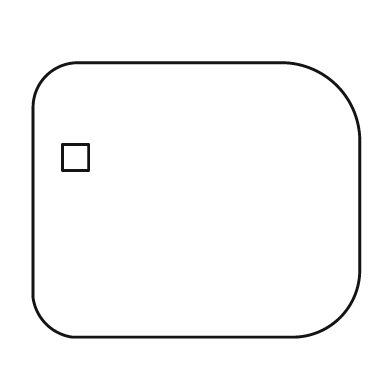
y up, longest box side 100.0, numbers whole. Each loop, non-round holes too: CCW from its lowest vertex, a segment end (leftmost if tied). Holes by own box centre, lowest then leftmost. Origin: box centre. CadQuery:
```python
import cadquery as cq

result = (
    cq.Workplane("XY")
    .moveTo(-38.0, -42.0)
    .lineTo(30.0, -42.0)
    .threePointArc((44.0, -36.0), (50.0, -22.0))
    .lineTo(50.0, 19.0)
    .threePointArc((43.0, 35.0), (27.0, 42.0))
    .lineTo(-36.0, 42.0)
    .threePointArc((-46.0, 38.0), (-50.0, 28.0))
    .lineTo(-50.0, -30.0)
    .threePointArc((-46.0, -38.0), (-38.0, -42.0))
    .close()
    .moveTo(-41.0, 9.0)
    .lineTo(-33.0, 9.0)
    .lineTo(-33.0, 17.0)
    .lineTo(-41.0, 17.0)
    .close()
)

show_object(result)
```